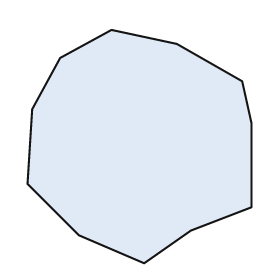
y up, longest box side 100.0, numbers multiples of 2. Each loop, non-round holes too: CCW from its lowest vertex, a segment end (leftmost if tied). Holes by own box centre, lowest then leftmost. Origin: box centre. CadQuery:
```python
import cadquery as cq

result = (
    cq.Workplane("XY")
    .moveTo(2.0, -50.0)
    .lineTo(22.0, -36.0)
    .lineTo(48.0, -26.0)
    .lineTo(48.0, 10.0)
    .lineTo(44.0, 28.0)
    .lineTo(16.0, 44.0)
    .lineTo(-12.0, 50.0)
    .lineTo(-34.0, 38.0)
    .lineTo(-46.0, 16.0)
    .lineTo(-48.0, -16.0)
    .lineTo(-26.0, -38.0)
    .close()
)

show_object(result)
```